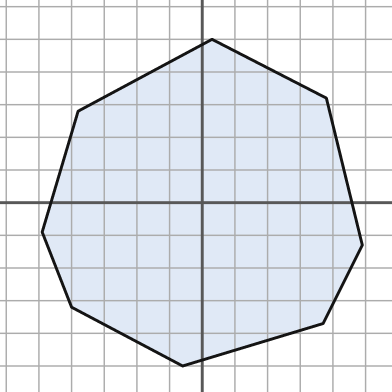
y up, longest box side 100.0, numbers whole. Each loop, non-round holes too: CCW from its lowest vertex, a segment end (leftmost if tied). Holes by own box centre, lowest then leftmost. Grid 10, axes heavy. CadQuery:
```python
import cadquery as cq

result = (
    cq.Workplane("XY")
    .moveTo(-6.0, -50.0)
    .lineTo(37.0, -37.0)
    .lineTo(49.0, -13.0)
    .lineTo(38.0, 32.0)
    .lineTo(3.0, 50.0)
    .lineTo(-38.0, 28.0)
    .lineTo(-49.0, -9.0)
    .lineTo(-40.0, -32.0)
    .close()
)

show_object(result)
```